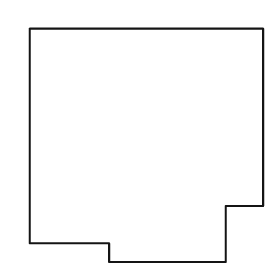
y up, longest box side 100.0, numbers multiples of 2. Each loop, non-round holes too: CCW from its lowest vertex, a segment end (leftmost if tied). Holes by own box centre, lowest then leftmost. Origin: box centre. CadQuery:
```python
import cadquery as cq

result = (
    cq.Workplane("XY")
    .moveTo(-16.0, -50.0)
    .lineTo(34.0, -50.0)
    .lineTo(34.0, -26.0)
    .lineTo(50.0, -26.0)
    .lineTo(50.0, 50.0)
    .lineTo(-50.0, 50.0)
    .lineTo(-50.0, -42.0)
    .lineTo(-16.0, -42.0)
    .close()
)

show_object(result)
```